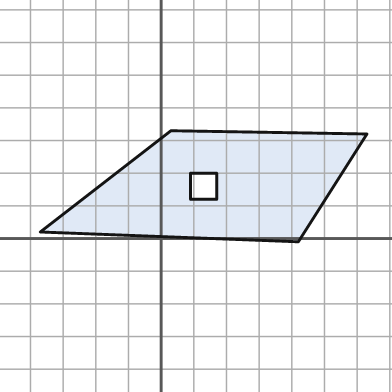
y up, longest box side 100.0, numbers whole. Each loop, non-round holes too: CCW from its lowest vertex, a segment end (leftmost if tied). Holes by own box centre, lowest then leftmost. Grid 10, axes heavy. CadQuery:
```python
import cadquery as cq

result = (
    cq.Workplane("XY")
    .moveTo(42.0, -1.0)
    .lineTo(63.0, 32.0)
    .lineTo(3.0, 33.0)
    .lineTo(-37.0, 2.0)
    .close()
    .moveTo(9.0, 12.0)
    .lineTo(17.0, 12.0)
    .lineTo(17.0, 20.0)
    .lineTo(9.0, 20.0)
    .close()
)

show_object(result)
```